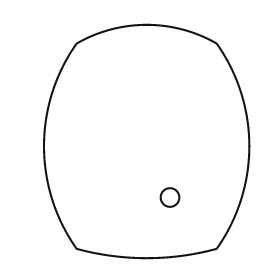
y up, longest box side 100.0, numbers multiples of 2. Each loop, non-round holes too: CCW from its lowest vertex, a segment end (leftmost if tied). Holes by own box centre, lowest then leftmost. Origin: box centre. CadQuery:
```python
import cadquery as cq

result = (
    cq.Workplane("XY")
    .moveTo(-30.0, -46.0)
    .threePointArc((0.0, -50.0), (30.0, -46.0))
    .threePointArc((44.0, -2.0), (30.0, 42.0))
    .threePointArc((0.0, 50.0), (-30.0, 42.0))
    .threePointArc((-44.0, -2.0), (-30.0, -46.0))
    .close()
    .moveTo(10.0, -24.0)
    .circle(4.0)
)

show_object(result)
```